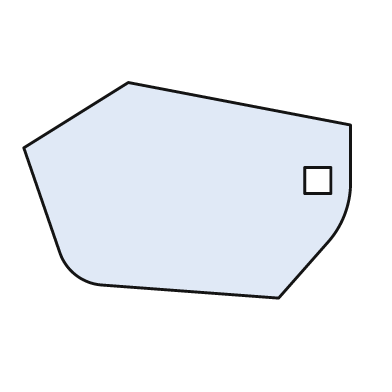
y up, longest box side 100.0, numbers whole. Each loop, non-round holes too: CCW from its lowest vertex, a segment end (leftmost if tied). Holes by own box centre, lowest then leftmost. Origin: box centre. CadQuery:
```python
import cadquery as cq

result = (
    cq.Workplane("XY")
    .moveTo(28.0, -33.0)
    .lineTo(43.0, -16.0)
    .threePointArc((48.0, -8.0), (50.0, 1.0))
    .lineTo(50.0, 20.0)
    .lineTo(-18.0, 33.0)
    .lineTo(-50.0, 13.0)
    .lineTo(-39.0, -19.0)
    .threePointArc((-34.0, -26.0), (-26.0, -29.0))
    .close()
    .moveTo(36.0, -1.0)
    .lineTo(44.0, -1.0)
    .lineTo(44.0, 7.0)
    .lineTo(36.0, 7.0)
    .close()
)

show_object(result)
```